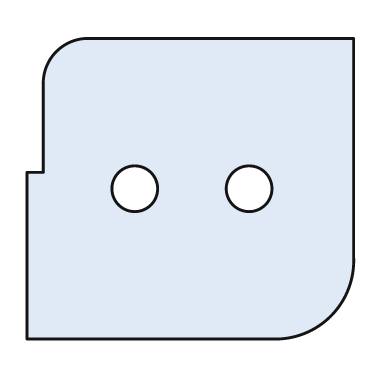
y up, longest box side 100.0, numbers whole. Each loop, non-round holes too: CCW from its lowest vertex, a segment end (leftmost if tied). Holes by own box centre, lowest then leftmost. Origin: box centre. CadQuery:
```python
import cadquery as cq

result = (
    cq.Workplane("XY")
    .moveTo(-50.0, -46.0)
    .lineTo(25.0, -46.0)
    .threePointArc((43.0, -39.0), (50.0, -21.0))
    .lineTo(50.0, 46.0)
    .lineTo(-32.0, 46.0)
    .threePointArc((-41.0, 42.0), (-45.0, 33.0))
    .lineTo(-45.0, 5.0)
    .lineTo(-50.0, 5.0)
    .close()
    .moveTo(-17.0, 0.0)
    .circle(7.0)
    .moveTo(18.0, 0.0)
    .circle(7.0)
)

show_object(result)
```